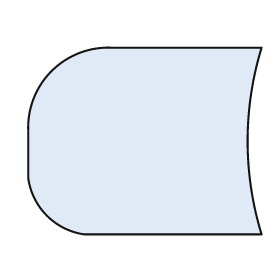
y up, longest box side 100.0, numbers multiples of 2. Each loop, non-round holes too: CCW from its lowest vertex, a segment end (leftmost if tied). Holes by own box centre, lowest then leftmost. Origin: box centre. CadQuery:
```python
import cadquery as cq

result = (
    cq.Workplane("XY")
    .moveTo(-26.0, -40.0)
    .lineTo(50.0, -40.0)
    .threePointArc((44.0, 0.0), (50.0, 40.0))
    .lineTo(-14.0, 40.0)
    .threePointArc((-40.0, 30.0), (-50.0, 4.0))
    .lineTo(-50.0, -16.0)
    .threePointArc((-42.0, -32.0), (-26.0, -40.0))
    .close()
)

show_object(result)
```